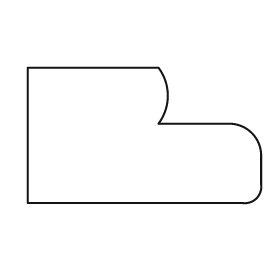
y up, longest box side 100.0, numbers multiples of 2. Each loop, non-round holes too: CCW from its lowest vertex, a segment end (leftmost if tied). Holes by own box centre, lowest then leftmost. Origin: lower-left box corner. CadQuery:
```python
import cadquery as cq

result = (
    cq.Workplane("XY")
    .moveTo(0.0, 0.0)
    .lineTo(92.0, 0.0)
    .threePointArc((98.0, 2.0), (100.0, 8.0))
    .lineTo(100.0, 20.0)
    .threePointArc((96.0, 30.0), (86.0, 34.0))
    .lineTo(56.0, 34.0)
    .threePointArc((60.0, 46.0), (56.0, 58.0))
    .lineTo(0.0, 58.0)
    .close()
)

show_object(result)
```